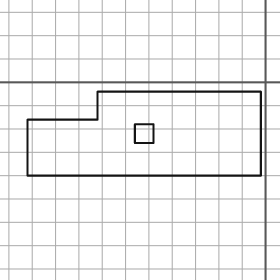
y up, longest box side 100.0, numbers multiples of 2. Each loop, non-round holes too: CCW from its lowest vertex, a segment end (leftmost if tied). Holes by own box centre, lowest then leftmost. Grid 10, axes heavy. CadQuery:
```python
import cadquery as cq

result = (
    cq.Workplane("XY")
    .moveTo(-102.0, -40.0)
    .lineTo(-2.0, -40.0)
    .lineTo(-2.0, -4.0)
    .lineTo(-72.0, -4.0)
    .lineTo(-72.0, -16.0)
    .lineTo(-102.0, -16.0)
    .close()
    .moveTo(-56.0, -26.0)
    .lineTo(-48.0, -26.0)
    .lineTo(-48.0, -18.0)
    .lineTo(-56.0, -18.0)
    .close()
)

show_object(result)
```